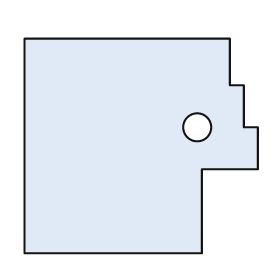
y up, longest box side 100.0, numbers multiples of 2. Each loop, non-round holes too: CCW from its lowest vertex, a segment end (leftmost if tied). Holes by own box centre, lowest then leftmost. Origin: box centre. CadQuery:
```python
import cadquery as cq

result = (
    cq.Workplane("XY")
    .moveTo(-50.0, -46.0)
    .lineTo(26.0, -46.0)
    .lineTo(26.0, -10.0)
    .lineTo(50.0, -10.0)
    .lineTo(50.0, 8.0)
    .lineTo(44.0, 8.0)
    .lineTo(44.0, 26.0)
    .lineTo(38.0, 26.0)
    .lineTo(38.0, 46.0)
    .lineTo(-50.0, 46.0)
    .close()
    .moveTo(24.0, 8.0)
    .circle(6.0)
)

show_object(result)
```